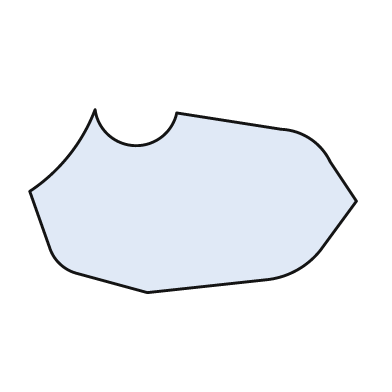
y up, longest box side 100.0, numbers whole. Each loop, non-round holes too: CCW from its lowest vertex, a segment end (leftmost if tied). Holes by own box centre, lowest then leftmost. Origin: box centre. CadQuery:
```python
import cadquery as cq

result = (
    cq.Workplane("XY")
    .moveTo(-14.0, -28.0)
    .lineTo(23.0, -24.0)
    .threePointArc((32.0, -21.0), (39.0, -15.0))
    .lineTo(50.0, 0.0)
    .lineTo(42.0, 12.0)
    .threePointArc((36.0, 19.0), (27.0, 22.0))
    .lineTo(-5.0, 27.0)
    .threePointArc((-18.0, 17.0), (-30.0, 28.0))
    .threePointArc((-38.0, 14.0), (-50.0, 3.0))
    .lineTo(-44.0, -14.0)
    .threePointArc((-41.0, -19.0), (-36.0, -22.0))
    .close()
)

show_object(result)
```